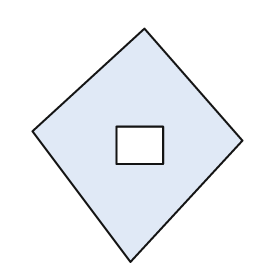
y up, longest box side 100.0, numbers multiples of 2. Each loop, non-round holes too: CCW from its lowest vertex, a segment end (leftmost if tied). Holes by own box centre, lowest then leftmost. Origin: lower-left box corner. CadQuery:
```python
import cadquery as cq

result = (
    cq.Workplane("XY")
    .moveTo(42.0, 0.0)
    .lineTo(90.0, 52.0)
    .lineTo(48.0, 100.0)
    .lineTo(0.0, 56.0)
    .close()
    .moveTo(36.0, 42.0)
    .lineTo(56.0, 42.0)
    .lineTo(56.0, 58.0)
    .lineTo(36.0, 58.0)
    .close()
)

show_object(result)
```